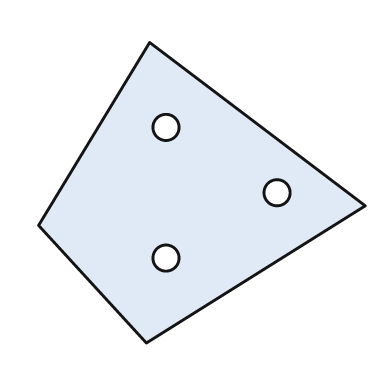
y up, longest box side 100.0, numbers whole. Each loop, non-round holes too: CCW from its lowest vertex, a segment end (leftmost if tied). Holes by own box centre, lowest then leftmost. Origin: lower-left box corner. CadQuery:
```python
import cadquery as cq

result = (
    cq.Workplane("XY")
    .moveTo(33.0, 0.0)
    .lineTo(100.0, 42.0)
    .lineTo(34.0, 92.0)
    .lineTo(0.0, 36.0)
    .close()
    .moveTo(39.0, 26.0)
    .circle(4.0)
    .moveTo(73.0, 46.0)
    .circle(4.0)
    .moveTo(39.0, 66.0)
    .circle(4.0)
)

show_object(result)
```